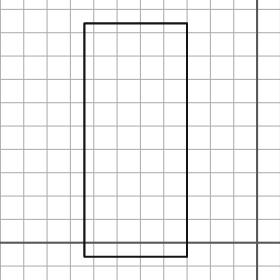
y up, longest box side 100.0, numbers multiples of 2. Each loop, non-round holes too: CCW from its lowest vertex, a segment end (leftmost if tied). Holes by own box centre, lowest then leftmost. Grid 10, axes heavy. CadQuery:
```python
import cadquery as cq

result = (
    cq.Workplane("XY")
    .moveTo(-74.0, -6.0)
    .lineTo(-30.0, -6.0)
    .lineTo(-30.0, 94.0)
    .lineTo(-74.0, 94.0)
    .close()
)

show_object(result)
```